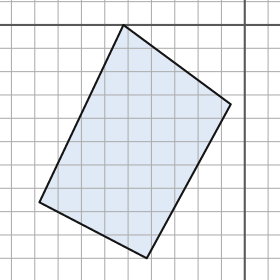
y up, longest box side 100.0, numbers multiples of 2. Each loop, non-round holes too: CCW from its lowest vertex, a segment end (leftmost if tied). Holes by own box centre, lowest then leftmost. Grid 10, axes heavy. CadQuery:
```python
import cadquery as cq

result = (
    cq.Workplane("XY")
    .moveTo(-42.0, -100.0)
    .lineTo(-6.0, -34.0)
    .lineTo(-52.0, 0.0)
    .lineTo(-88.0, -76.0)
    .close()
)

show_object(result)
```